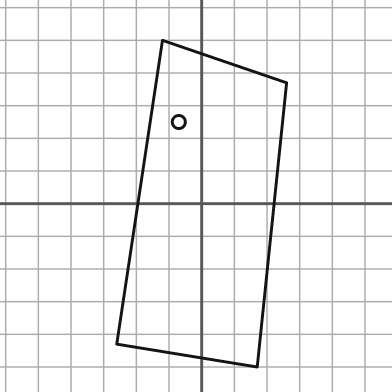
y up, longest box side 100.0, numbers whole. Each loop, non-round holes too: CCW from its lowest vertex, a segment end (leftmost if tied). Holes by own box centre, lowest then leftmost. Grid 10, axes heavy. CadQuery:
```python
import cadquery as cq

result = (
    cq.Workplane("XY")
    .moveTo(17.0, -50.0)
    .lineTo(26.0, 37.0)
    .lineTo(-12.0, 50.0)
    .lineTo(-26.0, -43.0)
    .close()
    .moveTo(-7.0, 25.0)
    .circle(2.0)
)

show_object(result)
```